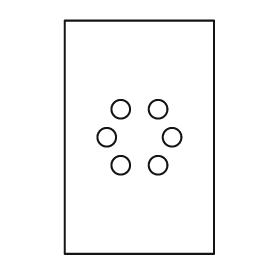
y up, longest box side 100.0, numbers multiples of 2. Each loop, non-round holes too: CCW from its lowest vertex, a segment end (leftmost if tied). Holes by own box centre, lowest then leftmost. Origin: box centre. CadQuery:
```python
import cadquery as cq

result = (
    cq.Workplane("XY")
    .moveTo(-32.0, -50.0)
    .lineTo(32.0, -50.0)
    .lineTo(32.0, 50.0)
    .lineTo(-32.0, 50.0)
    .close()
    .moveTo(-8.0, -12.0)
    .circle(4.0)
    .moveTo(8.0, -12.0)
    .circle(4.0)
    .moveTo(-14.0, 0.0)
    .circle(4.0)
    .moveTo(14.0, 0.0)
    .circle(4.0)
    .moveTo(-8.0, 12.0)
    .circle(4.0)
    .moveTo(8.0, 12.0)
    .circle(4.0)
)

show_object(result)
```